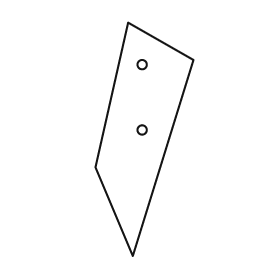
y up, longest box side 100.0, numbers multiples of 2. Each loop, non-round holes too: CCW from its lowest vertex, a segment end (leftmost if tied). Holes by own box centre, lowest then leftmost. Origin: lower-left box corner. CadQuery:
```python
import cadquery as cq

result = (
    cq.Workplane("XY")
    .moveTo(16.0, 0.0)
    .lineTo(42.0, 84.0)
    .lineTo(14.0, 100.0)
    .lineTo(0.0, 38.0)
    .close()
    .moveTo(20.0, 54.0)
    .circle(2.0)
    .moveTo(20.0, 82.0)
    .circle(2.0)
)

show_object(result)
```